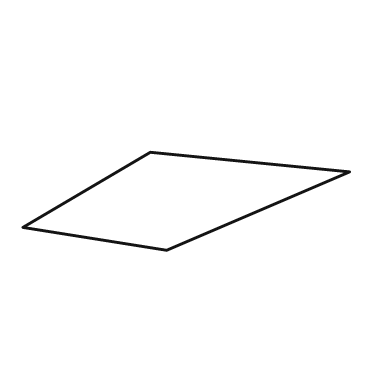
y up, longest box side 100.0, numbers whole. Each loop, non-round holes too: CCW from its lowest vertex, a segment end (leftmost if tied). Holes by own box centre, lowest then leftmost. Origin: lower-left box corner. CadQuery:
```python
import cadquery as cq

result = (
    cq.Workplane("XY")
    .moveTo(44.0, 0.0)
    .lineTo(100.0, 24.0)
    .lineTo(39.0, 30.0)
    .lineTo(0.0, 7.0)
    .close()
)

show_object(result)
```